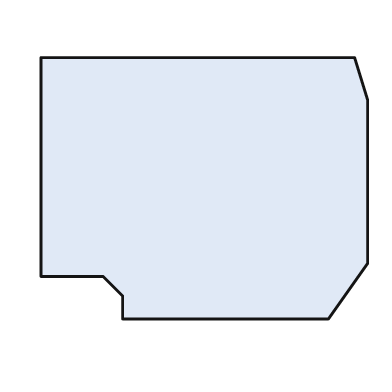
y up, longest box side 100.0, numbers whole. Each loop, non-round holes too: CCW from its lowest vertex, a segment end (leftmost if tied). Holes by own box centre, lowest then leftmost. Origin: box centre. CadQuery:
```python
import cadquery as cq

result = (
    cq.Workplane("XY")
    .moveTo(-25.0, -40.0)
    .lineTo(38.0, -40.0)
    .lineTo(50.0, -23.0)
    .lineTo(50.0, 27.0)
    .lineTo(46.0, 40.0)
    .lineTo(-50.0, 40.0)
    .lineTo(-50.0, -27.0)
    .lineTo(-31.0, -27.0)
    .lineTo(-25.0, -33.0)
    .close()
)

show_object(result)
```